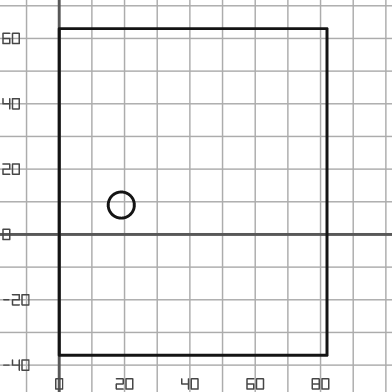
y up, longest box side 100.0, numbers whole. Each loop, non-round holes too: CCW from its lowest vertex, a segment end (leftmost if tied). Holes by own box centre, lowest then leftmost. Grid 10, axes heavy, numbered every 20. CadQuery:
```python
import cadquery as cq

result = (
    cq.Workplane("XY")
    .moveTo(0.0, -37.0)
    .lineTo(82.0, -37.0)
    .lineTo(82.0, 63.0)
    .lineTo(0.0, 63.0)
    .close()
    .moveTo(19.0, 9.0)
    .circle(4.0)
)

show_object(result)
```